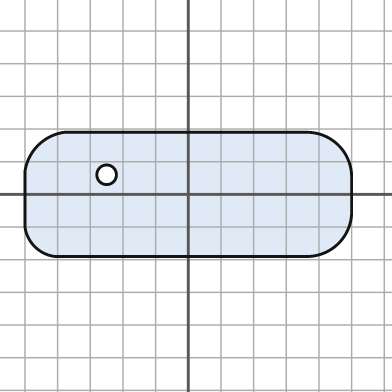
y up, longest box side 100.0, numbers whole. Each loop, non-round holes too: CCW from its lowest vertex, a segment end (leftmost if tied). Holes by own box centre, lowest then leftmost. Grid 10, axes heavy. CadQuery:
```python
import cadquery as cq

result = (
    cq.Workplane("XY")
    .moveTo(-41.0, -19.0)
    .lineTo(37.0, -19.0)
    .threePointArc((46.0, -15.0), (50.0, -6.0))
    .lineTo(50.0, 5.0)
    .threePointArc((46.0, 15.0), (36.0, 19.0))
    .lineTo(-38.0, 19.0)
    .threePointArc((-46.0, 15.0), (-50.0, 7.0))
    .lineTo(-50.0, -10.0)
    .threePointArc((-47.0, -16.0), (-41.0, -19.0))
    .close()
    .moveTo(-25.0, 6.0)
    .circle(3.0)
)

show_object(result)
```